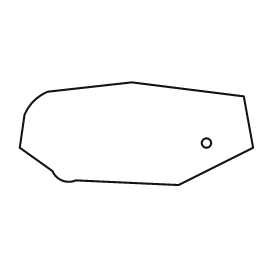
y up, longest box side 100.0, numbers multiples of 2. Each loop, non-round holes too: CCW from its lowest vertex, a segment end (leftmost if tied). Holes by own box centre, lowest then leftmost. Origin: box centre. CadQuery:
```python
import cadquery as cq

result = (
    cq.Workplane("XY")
    .moveTo(18.0, -22.0)
    .lineTo(50.0, -6.0)
    .lineTo(46.0, 16.0)
    .lineTo(-2.0, 22.0)
    .lineTo(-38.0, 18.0)
    .threePointArc((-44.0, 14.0), (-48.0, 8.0))
    .lineTo(-50.0, -6.0)
    .lineTo(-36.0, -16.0)
    .threePointArc((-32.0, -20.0), (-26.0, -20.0))
    .close()
    .moveTo(30.0, -4.0)
    .circle(2.0)
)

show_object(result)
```